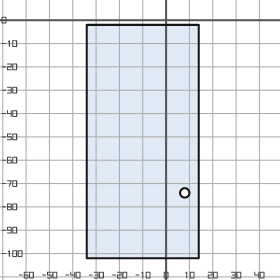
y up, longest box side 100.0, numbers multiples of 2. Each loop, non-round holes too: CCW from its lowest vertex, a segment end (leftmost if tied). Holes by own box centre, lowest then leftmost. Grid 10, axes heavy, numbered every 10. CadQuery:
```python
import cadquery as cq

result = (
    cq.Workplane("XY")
    .moveTo(-34.0, -102.0)
    .lineTo(14.0, -102.0)
    .lineTo(14.0, -2.0)
    .lineTo(-34.0, -2.0)
    .close()
    .moveTo(8.0, -74.0)
    .circle(2.0)
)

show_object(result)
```